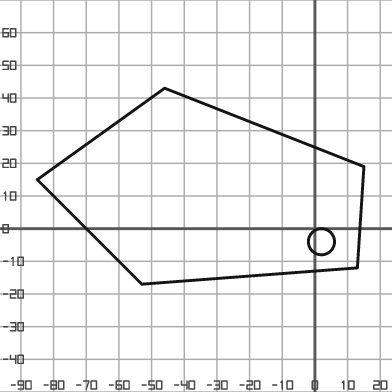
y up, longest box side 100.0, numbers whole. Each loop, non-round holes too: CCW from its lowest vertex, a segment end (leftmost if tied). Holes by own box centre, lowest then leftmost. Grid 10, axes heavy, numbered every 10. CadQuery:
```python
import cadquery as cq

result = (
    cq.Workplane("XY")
    .moveTo(-53.0, -17.0)
    .lineTo(13.0, -12.0)
    .lineTo(15.0, 19.0)
    .lineTo(-46.0, 43.0)
    .lineTo(-85.0, 15.0)
    .close()
    .moveTo(2.0, -4.0)
    .circle(4.0)
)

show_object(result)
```